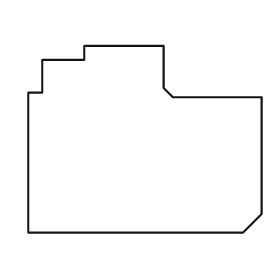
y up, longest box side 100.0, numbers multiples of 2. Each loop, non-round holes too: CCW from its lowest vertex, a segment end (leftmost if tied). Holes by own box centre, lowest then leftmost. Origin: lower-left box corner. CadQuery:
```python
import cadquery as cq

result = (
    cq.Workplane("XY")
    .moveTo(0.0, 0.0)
    .lineTo(92.0, 0.0)
    .lineTo(100.0, 8.0)
    .lineTo(100.0, 58.0)
    .lineTo(62.0, 58.0)
    .lineTo(58.0, 62.0)
    .lineTo(58.0, 80.0)
    .lineTo(24.0, 80.0)
    .lineTo(24.0, 74.0)
    .lineTo(6.0, 74.0)
    .lineTo(6.0, 60.0)
    .lineTo(0.0, 60.0)
    .close()
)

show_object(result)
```